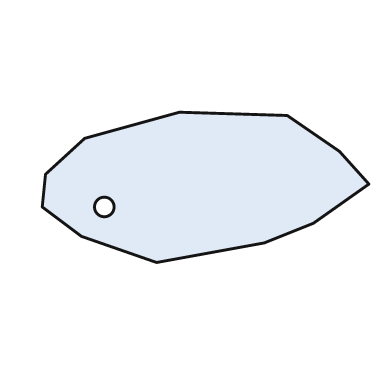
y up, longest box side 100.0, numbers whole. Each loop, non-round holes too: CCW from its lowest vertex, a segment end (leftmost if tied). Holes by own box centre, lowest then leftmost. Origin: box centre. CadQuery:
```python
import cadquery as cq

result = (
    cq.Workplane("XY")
    .moveTo(-15.0, -23.0)
    .lineTo(18.0, -17.0)
    .lineTo(33.0, -11.0)
    .lineTo(50.0, 1.0)
    .lineTo(41.0, 11.0)
    .lineTo(25.0, 22.0)
    .lineTo(-8.0, 23.0)
    .lineTo(-37.0, 15.0)
    .lineTo(-49.0, 4.0)
    .lineTo(-50.0, -6.0)
    .lineTo(-38.0, -15.0)
    .close()
    .moveTo(-31.0, -6.0)
    .circle(3.0)
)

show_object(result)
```